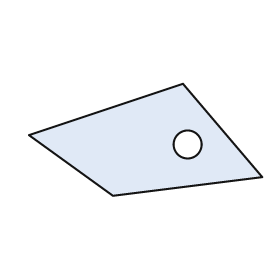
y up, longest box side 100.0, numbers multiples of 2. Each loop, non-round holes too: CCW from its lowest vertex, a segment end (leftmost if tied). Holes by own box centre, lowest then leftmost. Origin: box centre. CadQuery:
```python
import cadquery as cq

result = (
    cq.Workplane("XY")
    .moveTo(-14.0, -24.0)
    .lineTo(50.0, -16.0)
    .lineTo(16.0, 24.0)
    .lineTo(-50.0, 2.0)
    .close()
    .moveTo(18.0, -2.0)
    .circle(6.0)
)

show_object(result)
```